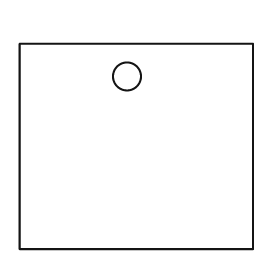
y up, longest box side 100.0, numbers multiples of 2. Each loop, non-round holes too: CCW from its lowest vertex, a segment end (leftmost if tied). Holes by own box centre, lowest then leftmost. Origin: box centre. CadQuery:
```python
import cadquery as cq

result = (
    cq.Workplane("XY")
    .moveTo(-50.0, -44.0)
    .lineTo(50.0, -44.0)
    .lineTo(50.0, 44.0)
    .lineTo(-50.0, 44.0)
    .close()
    .moveTo(-4.0, 30.0)
    .circle(6.0)
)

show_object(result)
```